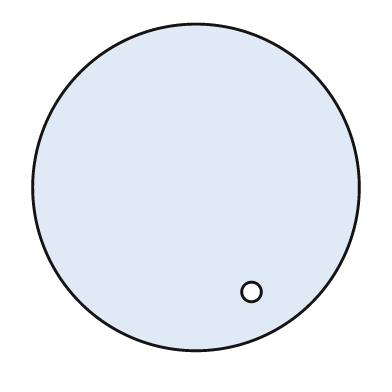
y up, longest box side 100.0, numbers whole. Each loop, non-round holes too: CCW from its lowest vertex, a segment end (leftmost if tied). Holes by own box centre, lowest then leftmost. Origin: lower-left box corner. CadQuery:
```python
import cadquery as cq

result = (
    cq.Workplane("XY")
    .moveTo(50.0, 50.0)
    .circle(50.0)
    .moveTo(67.0, 18.0)
    .circle(3.0)
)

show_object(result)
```